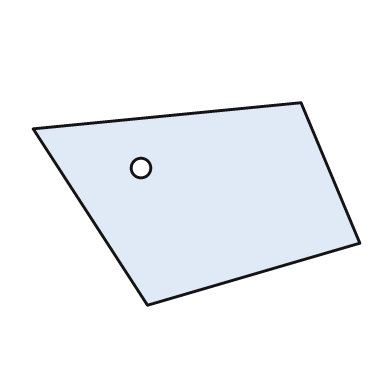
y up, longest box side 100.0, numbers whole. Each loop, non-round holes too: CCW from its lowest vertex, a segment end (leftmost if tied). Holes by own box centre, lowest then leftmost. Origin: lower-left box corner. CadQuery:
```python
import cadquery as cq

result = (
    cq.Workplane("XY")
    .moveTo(35.0, 0.0)
    .lineTo(100.0, 19.0)
    .lineTo(82.0, 62.0)
    .lineTo(0.0, 54.0)
    .close()
    .moveTo(33.0, 42.0)
    .circle(3.0)
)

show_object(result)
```